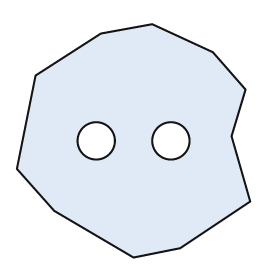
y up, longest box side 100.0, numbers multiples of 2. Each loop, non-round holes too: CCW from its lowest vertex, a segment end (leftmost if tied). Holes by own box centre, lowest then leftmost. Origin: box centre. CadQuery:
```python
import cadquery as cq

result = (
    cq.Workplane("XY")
    .moveTo(0.0, -50.0)
    .lineTo(20.0, -46.0)
    .lineTo(50.0, -26.0)
    .lineTo(42.0, 2.0)
    .lineTo(48.0, 22.0)
    .lineTo(34.0, 38.0)
    .lineTo(8.0, 50.0)
    .lineTo(-14.0, 46.0)
    .lineTo(-42.0, 28.0)
    .lineTo(-50.0, -12.0)
    .lineTo(-34.0, -30.0)
    .close()
    .moveTo(-16.0, 0.0)
    .circle(8.0)
    .moveTo(16.0, 0.0)
    .circle(8.0)
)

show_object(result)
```